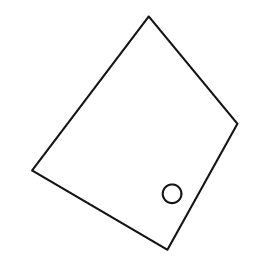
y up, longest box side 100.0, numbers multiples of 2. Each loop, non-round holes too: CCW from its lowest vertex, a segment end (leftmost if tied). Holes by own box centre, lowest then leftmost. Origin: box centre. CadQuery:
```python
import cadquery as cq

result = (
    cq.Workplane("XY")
    .moveTo(14.0, -50.0)
    .lineTo(44.0, 4.0)
    .lineTo(6.0, 50.0)
    .lineTo(-44.0, -16.0)
    .close()
    .moveTo(16.0, -26.0)
    .circle(4.0)
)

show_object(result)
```